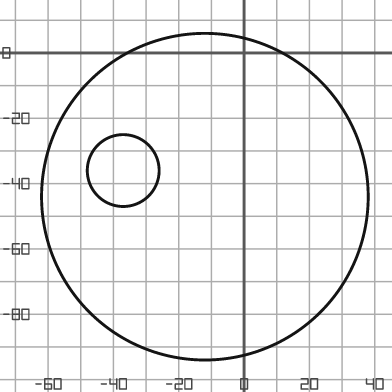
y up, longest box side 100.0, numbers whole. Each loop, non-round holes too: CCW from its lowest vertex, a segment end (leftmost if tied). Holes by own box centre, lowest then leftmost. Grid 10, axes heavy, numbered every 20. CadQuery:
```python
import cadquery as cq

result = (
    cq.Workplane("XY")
    .moveTo(-12.0, -44.0)
    .circle(50.0)
    .moveTo(-37.0, -36.0)
    .circle(11.0)
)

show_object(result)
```